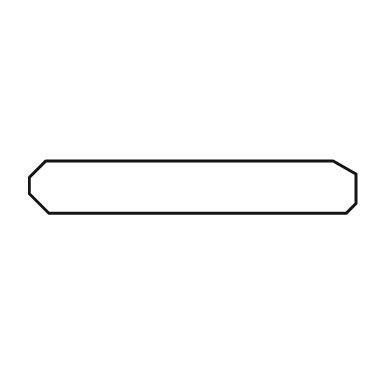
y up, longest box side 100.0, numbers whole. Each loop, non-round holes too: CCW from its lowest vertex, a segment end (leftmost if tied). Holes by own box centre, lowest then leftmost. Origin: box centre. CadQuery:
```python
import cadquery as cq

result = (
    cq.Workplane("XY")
    .moveTo(-44.0, -8.0)
    .lineTo(47.0, -8.0)
    .lineTo(50.0, -5.0)
    .lineTo(50.0, 4.0)
    .lineTo(43.0, 8.0)
    .lineTo(-45.0, 8.0)
    .lineTo(-50.0, 3.0)
    .lineTo(-50.0, -2.0)
    .close()
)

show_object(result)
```